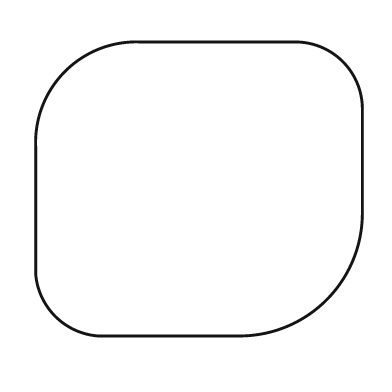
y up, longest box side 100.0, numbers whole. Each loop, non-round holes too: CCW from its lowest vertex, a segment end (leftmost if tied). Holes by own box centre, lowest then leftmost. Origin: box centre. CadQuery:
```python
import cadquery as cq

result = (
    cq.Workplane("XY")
    .moveTo(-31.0, -45.0)
    .lineTo(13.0, -45.0)
    .threePointArc((39.0, -34.0), (50.0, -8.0))
    .lineTo(50.0, 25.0)
    .threePointArc((44.0, 39.0), (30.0, 45.0))
    .lineTo(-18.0, 45.0)
    .threePointArc((-41.0, 36.0), (-50.0, 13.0))
    .lineTo(-50.0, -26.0)
    .threePointArc((-44.0, -39.0), (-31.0, -45.0))
    .close()
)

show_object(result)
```